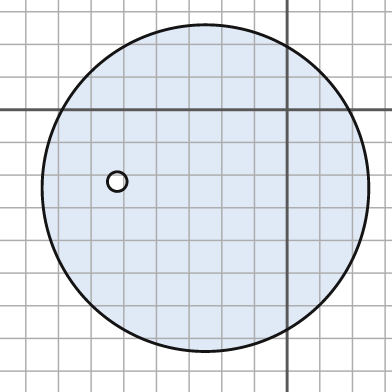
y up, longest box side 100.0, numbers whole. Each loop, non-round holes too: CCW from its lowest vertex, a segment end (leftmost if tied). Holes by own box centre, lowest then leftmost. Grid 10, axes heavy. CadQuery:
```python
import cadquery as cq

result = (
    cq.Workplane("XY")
    .moveTo(-25.0, -24.0)
    .circle(50.0)
    .moveTo(-52.0, -22.0)
    .circle(3.0)
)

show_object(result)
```